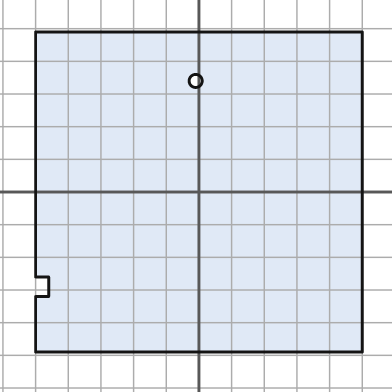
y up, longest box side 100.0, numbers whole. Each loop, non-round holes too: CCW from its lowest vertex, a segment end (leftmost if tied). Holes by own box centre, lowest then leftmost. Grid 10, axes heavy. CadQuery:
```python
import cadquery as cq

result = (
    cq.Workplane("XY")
    .moveTo(-50.0, -49.0)
    .lineTo(50.0, -49.0)
    .lineTo(50.0, 49.0)
    .lineTo(-50.0, 49.0)
    .lineTo(-50.0, -26.0)
    .lineTo(-46.0, -26.0)
    .lineTo(-46.0, -32.0)
    .lineTo(-50.0, -32.0)
    .close()
    .moveTo(-1.0, 34.0)
    .circle(2.0)
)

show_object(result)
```